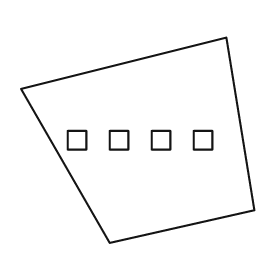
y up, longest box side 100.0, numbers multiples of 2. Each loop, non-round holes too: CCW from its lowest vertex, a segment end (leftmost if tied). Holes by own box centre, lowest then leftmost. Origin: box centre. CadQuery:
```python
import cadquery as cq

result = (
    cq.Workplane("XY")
    .moveTo(-12.0, -44.0)
    .lineTo(50.0, -30.0)
    .lineTo(38.0, 44.0)
    .lineTo(-50.0, 22.0)
    .close()
    .moveTo(-30.0, -4.0)
    .lineTo(-22.0, -4.0)
    .lineTo(-22.0, 4.0)
    .lineTo(-30.0, 4.0)
    .close()
    .moveTo(-12.0, -4.0)
    .lineTo(-4.0, -4.0)
    .lineTo(-4.0, 4.0)
    .lineTo(-12.0, 4.0)
    .close()
    .moveTo(6.0, -4.0)
    .lineTo(14.0, -4.0)
    .lineTo(14.0, 4.0)
    .lineTo(6.0, 4.0)
    .close()
    .moveTo(24.0, -4.0)
    .lineTo(32.0, -4.0)
    .lineTo(32.0, 4.0)
    .lineTo(24.0, 4.0)
    .close()
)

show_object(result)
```